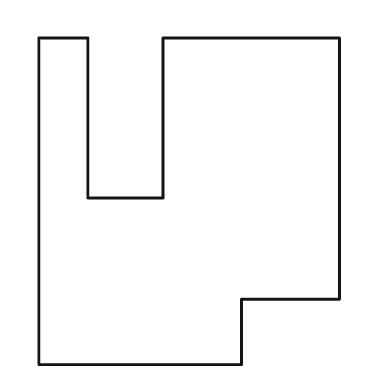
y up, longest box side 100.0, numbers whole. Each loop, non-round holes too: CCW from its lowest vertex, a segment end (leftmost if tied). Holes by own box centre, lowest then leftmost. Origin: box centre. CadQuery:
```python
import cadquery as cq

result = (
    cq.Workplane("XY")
    .moveTo(-46.0, -50.0)
    .lineTo(16.0, -50.0)
    .lineTo(16.0, -30.0)
    .lineTo(46.0, -30.0)
    .lineTo(46.0, 50.0)
    .lineTo(-8.0, 50.0)
    .lineTo(-8.0, 1.0)
    .lineTo(-31.0, 1.0)
    .lineTo(-31.0, 50.0)
    .lineTo(-46.0, 50.0)
    .close()
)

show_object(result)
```